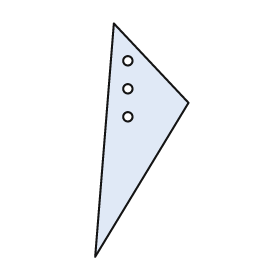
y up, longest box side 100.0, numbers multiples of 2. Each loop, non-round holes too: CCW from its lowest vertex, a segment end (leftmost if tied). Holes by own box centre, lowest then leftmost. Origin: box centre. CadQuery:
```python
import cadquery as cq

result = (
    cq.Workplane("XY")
    .moveTo(-20.0, -50.0)
    .lineTo(20.0, 16.0)
    .lineTo(-12.0, 50.0)
    .close()
    .moveTo(-6.0, 10.0)
    .circle(2.0)
    .moveTo(-6.0, 22.0)
    .circle(2.0)
    .moveTo(-6.0, 34.0)
    .circle(2.0)
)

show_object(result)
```